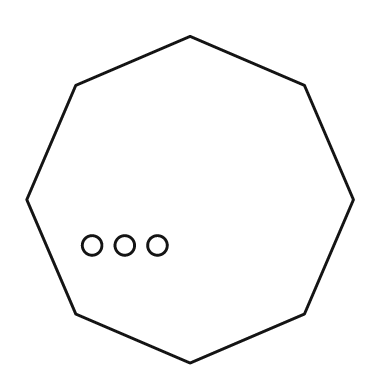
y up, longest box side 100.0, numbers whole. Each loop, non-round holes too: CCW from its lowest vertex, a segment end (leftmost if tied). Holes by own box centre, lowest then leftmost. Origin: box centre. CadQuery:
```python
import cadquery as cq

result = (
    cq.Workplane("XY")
    .moveTo(0.0, -50.0)
    .lineTo(35.0, -35.0)
    .lineTo(50.0, 0.0)
    .lineTo(35.0, 35.0)
    .lineTo(0.0, 50.0)
    .lineTo(-35.0, 35.0)
    .lineTo(-50.0, 0.0)
    .lineTo(-35.0, -35.0)
    .close()
    .moveTo(-30.0, -14.0)
    .circle(3.0)
    .moveTo(-20.0, -14.0)
    .circle(3.0)
    .moveTo(-10.0, -14.0)
    .circle(3.0)
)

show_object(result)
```